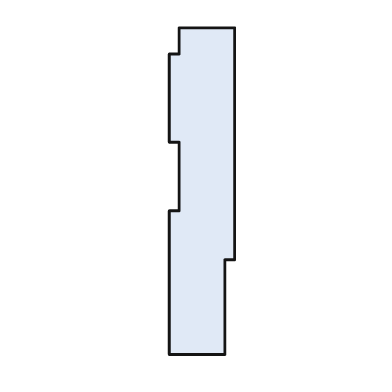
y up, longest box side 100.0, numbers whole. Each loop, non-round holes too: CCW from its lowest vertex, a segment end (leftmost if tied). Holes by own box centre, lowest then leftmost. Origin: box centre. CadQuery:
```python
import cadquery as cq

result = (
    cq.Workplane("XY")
    .moveTo(-10.0, -50.0)
    .lineTo(7.0, -50.0)
    .lineTo(7.0, -21.0)
    .lineTo(10.0, -21.0)
    .lineTo(10.0, 50.0)
    .lineTo(-7.0, 50.0)
    .lineTo(-7.0, 42.0)
    .lineTo(-10.0, 42.0)
    .lineTo(-10.0, 15.0)
    .lineTo(-7.0, 15.0)
    .lineTo(-7.0, -6.0)
    .lineTo(-10.0, -6.0)
    .close()
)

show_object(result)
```